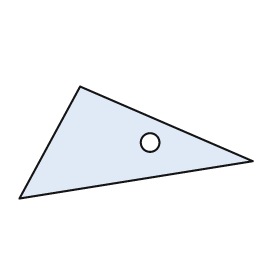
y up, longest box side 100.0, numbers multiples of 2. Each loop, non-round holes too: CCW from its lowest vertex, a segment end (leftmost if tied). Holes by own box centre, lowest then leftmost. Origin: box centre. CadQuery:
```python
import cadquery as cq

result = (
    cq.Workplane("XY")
    .moveTo(-50.0, -24.0)
    .lineTo(50.0, -8.0)
    .lineTo(-24.0, 24.0)
    .close()
    .moveTo(6.0, 0.0)
    .circle(4.0)
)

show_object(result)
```